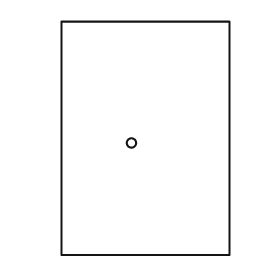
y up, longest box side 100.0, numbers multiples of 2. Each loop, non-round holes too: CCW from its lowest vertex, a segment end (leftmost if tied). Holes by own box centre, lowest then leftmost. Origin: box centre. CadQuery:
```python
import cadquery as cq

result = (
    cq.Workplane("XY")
    .moveTo(-36.0, -50.0)
    .lineTo(36.0, -50.0)
    .lineTo(36.0, 50.0)
    .lineTo(-36.0, 50.0)
    .close()
    .moveTo(-6.0, -2.0)
    .circle(2.0)
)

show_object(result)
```